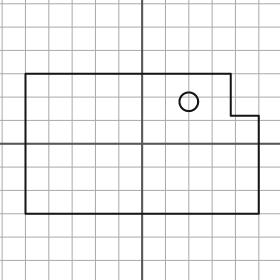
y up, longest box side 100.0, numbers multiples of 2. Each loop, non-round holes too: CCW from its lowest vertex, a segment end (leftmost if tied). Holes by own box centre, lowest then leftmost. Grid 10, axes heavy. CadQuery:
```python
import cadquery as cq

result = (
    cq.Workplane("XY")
    .moveTo(-50.0, -30.0)
    .lineTo(50.0, -30.0)
    .lineTo(50.0, 12.0)
    .lineTo(38.0, 12.0)
    .lineTo(38.0, 30.0)
    .lineTo(-50.0, 30.0)
    .close()
    .moveTo(20.0, 18.0)
    .circle(4.0)
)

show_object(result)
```